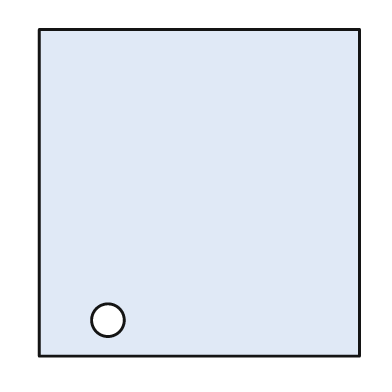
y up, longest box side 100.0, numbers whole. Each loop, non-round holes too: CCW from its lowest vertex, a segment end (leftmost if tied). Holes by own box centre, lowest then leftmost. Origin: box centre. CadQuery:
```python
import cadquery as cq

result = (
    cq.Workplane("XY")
    .moveTo(-49.0, -50.0)
    .lineTo(49.0, -50.0)
    .lineTo(49.0, 50.0)
    .lineTo(-49.0, 50.0)
    .close()
    .moveTo(-28.0, -39.0)
    .circle(5.0)
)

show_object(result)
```